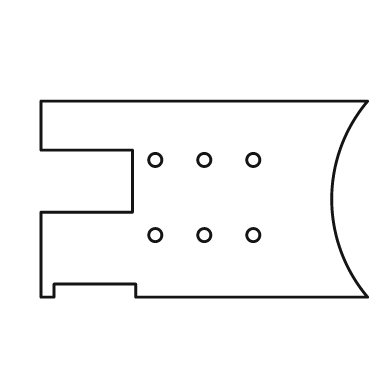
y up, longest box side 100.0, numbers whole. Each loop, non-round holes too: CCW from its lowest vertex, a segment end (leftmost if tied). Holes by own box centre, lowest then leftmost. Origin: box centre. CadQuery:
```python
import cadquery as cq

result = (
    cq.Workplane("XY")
    .moveTo(-50.0, -30.0)
    .lineTo(-46.0, -30.0)
    .lineTo(-46.0, -26.0)
    .lineTo(-21.0, -26.0)
    .lineTo(-21.0, -30.0)
    .lineTo(50.0, -30.0)
    .threePointArc((39.0, 0.0), (50.0, 30.0))
    .lineTo(-50.0, 30.0)
    .lineTo(-50.0, 15.0)
    .lineTo(-22.0, 15.0)
    .lineTo(-22.0, -4.0)
    .lineTo(-50.0, -4.0)
    .close()
    .moveTo(-15.0, -11.0)
    .circle(2.0)
    .moveTo(0.0, -11.0)
    .circle(2.0)
    .moveTo(15.0, -11.0)
    .circle(2.0)
    .moveTo(-15.0, 12.0)
    .circle(2.0)
    .moveTo(0.0, 12.0)
    .circle(2.0)
    .moveTo(15.0, 12.0)
    .circle(2.0)
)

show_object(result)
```